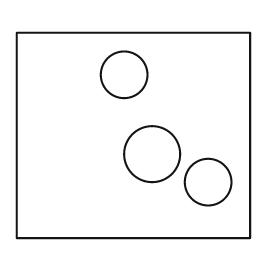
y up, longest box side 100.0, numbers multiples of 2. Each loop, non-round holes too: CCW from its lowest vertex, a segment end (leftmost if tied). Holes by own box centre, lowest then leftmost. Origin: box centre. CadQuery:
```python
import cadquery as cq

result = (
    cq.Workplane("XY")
    .moveTo(-50.0, -44.0)
    .lineTo(50.0, -44.0)
    .lineTo(50.0, 44.0)
    .lineTo(-50.0, 44.0)
    .close()
    .moveTo(32.0, -20.0)
    .circle(10.0)
    .moveTo(8.0, -8.0)
    .circle(12.0)
    .moveTo(-4.0, 26.0)
    .circle(10.0)
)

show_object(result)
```